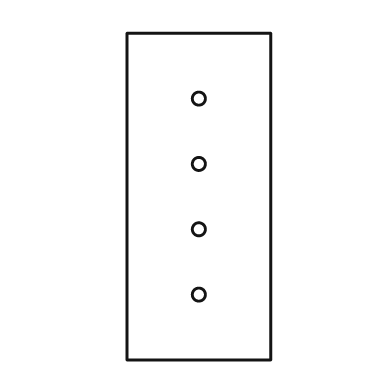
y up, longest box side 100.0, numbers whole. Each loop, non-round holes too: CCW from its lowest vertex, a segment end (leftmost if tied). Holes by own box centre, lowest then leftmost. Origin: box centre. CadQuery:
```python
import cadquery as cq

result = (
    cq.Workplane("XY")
    .moveTo(-22.0, -50.0)
    .lineTo(22.0, -50.0)
    .lineTo(22.0, 50.0)
    .lineTo(-22.0, 50.0)
    .close()
    .moveTo(0.0, -30.0)
    .circle(2.0)
    .moveTo(0.0, -10.0)
    .circle(2.0)
    .moveTo(0.0, 10.0)
    .circle(2.0)
    .moveTo(0.0, 30.0)
    .circle(2.0)
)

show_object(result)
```